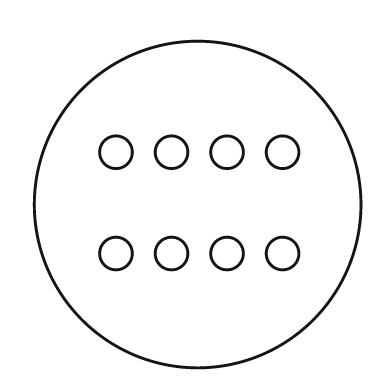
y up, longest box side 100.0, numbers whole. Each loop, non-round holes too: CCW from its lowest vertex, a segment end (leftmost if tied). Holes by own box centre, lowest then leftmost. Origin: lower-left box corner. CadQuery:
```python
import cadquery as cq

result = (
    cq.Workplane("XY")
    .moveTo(50.0, 50.0)
    .circle(50.0)
    .moveTo(25.0, 35.0)
    .circle(5.0)
    .moveTo(42.0, 35.0)
    .circle(5.0)
    .moveTo(59.0, 35.0)
    .circle(5.0)
    .moveTo(76.0, 35.0)
    .circle(5.0)
    .moveTo(25.0, 66.0)
    .circle(5.0)
    .moveTo(42.0, 66.0)
    .circle(5.0)
    .moveTo(59.0, 66.0)
    .circle(5.0)
    .moveTo(76.0, 66.0)
    .circle(5.0)
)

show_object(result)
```